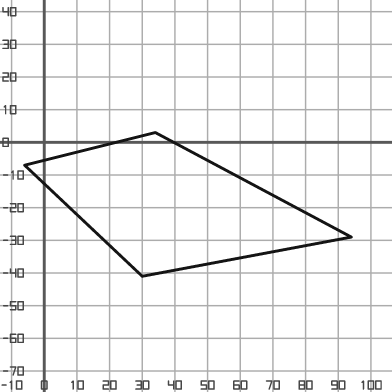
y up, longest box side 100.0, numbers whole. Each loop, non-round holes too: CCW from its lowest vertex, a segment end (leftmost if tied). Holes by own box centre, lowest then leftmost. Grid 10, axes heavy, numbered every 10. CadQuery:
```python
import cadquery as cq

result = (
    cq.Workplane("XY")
    .moveTo(30.0, -41.0)
    .lineTo(94.0, -29.0)
    .lineTo(34.0, 3.0)
    .lineTo(-6.0, -7.0)
    .close()
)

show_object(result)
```